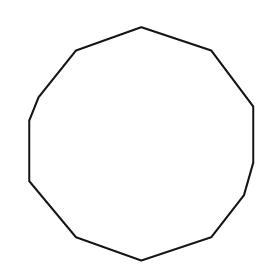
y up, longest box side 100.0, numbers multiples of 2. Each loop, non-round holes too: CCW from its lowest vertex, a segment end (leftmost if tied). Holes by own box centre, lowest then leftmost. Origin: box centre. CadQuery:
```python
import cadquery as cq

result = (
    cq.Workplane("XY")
    .moveTo(0.0, -50.0)
    .lineTo(30.0, -40.0)
    .lineTo(44.0, -22.0)
    .lineTo(48.0, -8.0)
    .lineTo(48.0, 16.0)
    .lineTo(30.0, 40.0)
    .lineTo(0.0, 50.0)
    .lineTo(-28.0, 40.0)
    .lineTo(-44.0, 20.0)
    .lineTo(-48.0, 10.0)
    .lineTo(-48.0, -16.0)
    .lineTo(-28.0, -40.0)
    .close()
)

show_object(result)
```